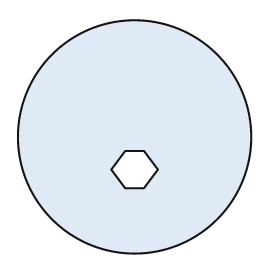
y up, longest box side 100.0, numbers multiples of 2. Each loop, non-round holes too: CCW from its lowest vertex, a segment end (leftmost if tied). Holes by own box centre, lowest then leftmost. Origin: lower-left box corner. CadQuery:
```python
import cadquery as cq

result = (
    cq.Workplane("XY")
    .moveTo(50.0, 50.0)
    .circle(50.0)
    .moveTo(46.0, 28.0)
    .lineTo(54.0, 28.0)
    .lineTo(60.0, 36.0)
    .lineTo(54.0, 44.0)
    .lineTo(46.0, 44.0)
    .lineTo(40.0, 36.0)
    .close()
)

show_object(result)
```